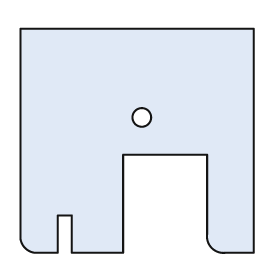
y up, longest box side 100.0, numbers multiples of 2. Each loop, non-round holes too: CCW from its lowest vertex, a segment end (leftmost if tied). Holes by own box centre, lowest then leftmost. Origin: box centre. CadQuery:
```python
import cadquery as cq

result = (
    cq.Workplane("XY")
    .moveTo(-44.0, -48.0)
    .lineTo(-34.0, -48.0)
    .lineTo(-34.0, -32.0)
    .lineTo(-28.0, -32.0)
    .lineTo(-28.0, -48.0)
    .lineTo(-6.0, -48.0)
    .lineTo(-6.0, -6.0)
    .lineTo(30.0, -6.0)
    .lineTo(30.0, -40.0)
    .threePointArc((32.0, -46.0), (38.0, -48.0))
    .lineTo(50.0, -48.0)
    .lineTo(50.0, 48.0)
    .lineTo(-50.0, 48.0)
    .lineTo(-50.0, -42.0)
    .threePointArc((-48.0, -46.0), (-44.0, -48.0))
    .close()
    .moveTo(2.0, 10.0)
    .circle(4.0)
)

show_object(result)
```